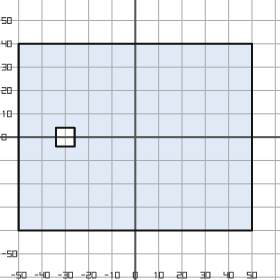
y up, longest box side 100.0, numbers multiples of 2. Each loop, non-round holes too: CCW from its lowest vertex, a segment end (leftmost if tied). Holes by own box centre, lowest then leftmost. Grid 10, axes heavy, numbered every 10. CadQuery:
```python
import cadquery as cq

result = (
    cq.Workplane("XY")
    .moveTo(-50.0, -40.0)
    .lineTo(50.0, -40.0)
    .lineTo(50.0, 40.0)
    .lineTo(-50.0, 40.0)
    .close()
    .moveTo(-34.0, -4.0)
    .lineTo(-26.0, -4.0)
    .lineTo(-26.0, 4.0)
    .lineTo(-34.0, 4.0)
    .close()
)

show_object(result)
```